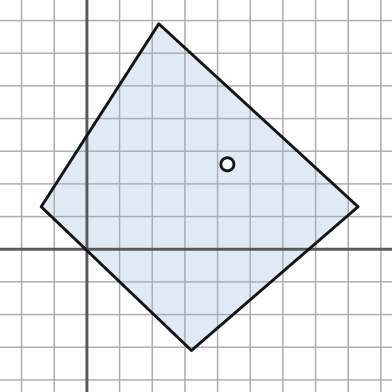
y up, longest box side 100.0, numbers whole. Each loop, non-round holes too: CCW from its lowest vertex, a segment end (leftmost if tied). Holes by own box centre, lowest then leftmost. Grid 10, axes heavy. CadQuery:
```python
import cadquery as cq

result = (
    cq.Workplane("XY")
    .moveTo(32.0, -31.0)
    .lineTo(83.0, 13.0)
    .lineTo(22.0, 69.0)
    .lineTo(-14.0, 13.0)
    .close()
    .moveTo(43.0, 26.0)
    .circle(2.0)
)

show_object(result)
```